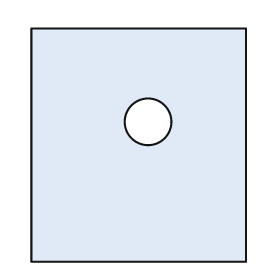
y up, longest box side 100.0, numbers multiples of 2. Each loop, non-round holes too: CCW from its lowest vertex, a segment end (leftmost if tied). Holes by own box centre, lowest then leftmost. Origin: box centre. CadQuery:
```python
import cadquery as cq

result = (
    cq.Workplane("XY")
    .moveTo(-46.0, -50.0)
    .lineTo(46.0, -50.0)
    .lineTo(46.0, 50.0)
    .lineTo(-46.0, 50.0)
    .close()
    .moveTo(4.0, 10.0)
    .circle(10.0)
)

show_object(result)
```